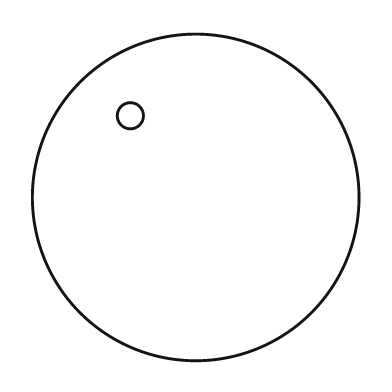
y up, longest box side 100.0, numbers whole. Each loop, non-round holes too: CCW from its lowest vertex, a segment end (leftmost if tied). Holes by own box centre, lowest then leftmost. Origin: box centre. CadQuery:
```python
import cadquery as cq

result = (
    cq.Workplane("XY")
    .moveTo(0.0, 0.0)
    .circle(50.0)
    .moveTo(-20.0, 25.0)
    .circle(4.0)
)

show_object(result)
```